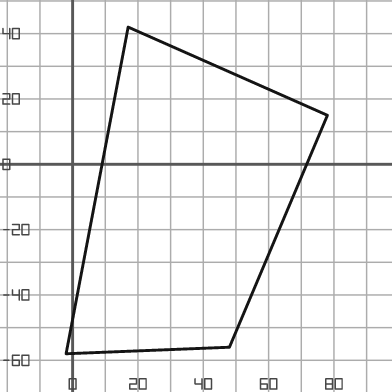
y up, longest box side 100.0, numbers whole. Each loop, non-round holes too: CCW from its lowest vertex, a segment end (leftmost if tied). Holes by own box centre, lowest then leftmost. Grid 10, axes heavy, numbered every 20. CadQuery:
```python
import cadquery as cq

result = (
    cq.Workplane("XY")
    .moveTo(-2.0, -58.0)
    .lineTo(48.0, -56.0)
    .lineTo(78.0, 15.0)
    .lineTo(17.0, 42.0)
    .close()
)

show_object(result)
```